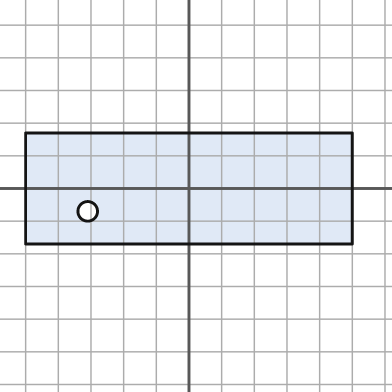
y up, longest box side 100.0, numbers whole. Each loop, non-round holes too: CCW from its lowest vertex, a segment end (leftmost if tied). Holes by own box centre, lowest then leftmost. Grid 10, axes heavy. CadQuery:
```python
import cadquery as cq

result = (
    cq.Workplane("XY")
    .moveTo(-50.0, -17.0)
    .lineTo(50.0, -17.0)
    .lineTo(50.0, 17.0)
    .lineTo(-50.0, 17.0)
    .close()
    .moveTo(-31.0, -7.0)
    .circle(3.0)
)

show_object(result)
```